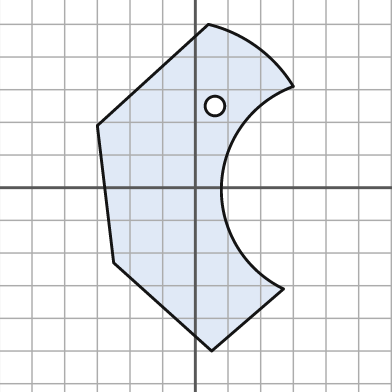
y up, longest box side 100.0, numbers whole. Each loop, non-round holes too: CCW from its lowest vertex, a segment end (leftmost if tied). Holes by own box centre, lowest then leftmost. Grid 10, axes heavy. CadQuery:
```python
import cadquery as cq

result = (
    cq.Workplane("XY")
    .moveTo(5.0, -50.0)
    .lineTo(27.0, -31.0)
    .threePointArc((8.0, 1.0), (30.0, 31.0))
    .threePointArc((19.0, 43.0), (4.0, 50.0))
    .lineTo(-30.0, 19.0)
    .lineTo(-25.0, -23.0)
    .close()
    .moveTo(6.0, 25.0)
    .circle(3.0)
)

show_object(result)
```